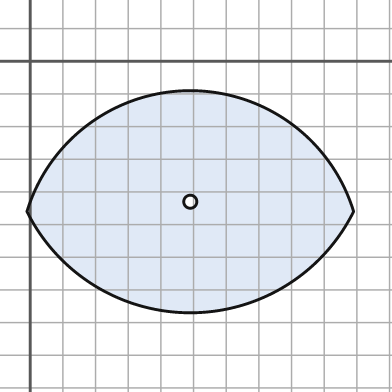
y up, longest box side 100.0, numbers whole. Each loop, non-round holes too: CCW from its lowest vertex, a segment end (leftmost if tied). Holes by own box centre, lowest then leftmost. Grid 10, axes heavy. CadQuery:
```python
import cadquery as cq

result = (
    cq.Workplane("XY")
    .moveTo(-1.0, -46.0)
    .threePointArc((49.0, -77.0), (99.0, -46.0))
    .threePointArc((49.0, -9.0), (-1.0, -46.0))
    .close()
    .moveTo(49.0, -43.0)
    .circle(2.0)
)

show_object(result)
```